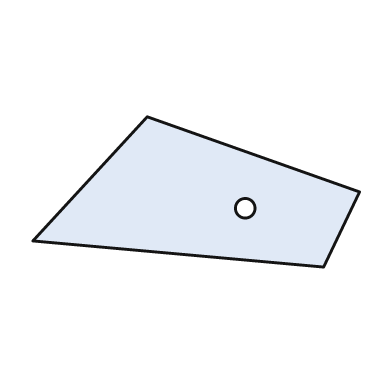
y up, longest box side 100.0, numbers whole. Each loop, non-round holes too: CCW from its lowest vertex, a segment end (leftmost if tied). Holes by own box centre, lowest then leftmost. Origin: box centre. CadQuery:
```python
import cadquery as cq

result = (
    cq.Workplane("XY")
    .moveTo(39.0, -23.0)
    .lineTo(50.0, 0.0)
    .lineTo(-15.0, 23.0)
    .lineTo(-50.0, -15.0)
    .close()
    .moveTo(15.0, -5.0)
    .circle(3.0)
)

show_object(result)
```